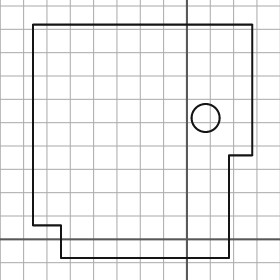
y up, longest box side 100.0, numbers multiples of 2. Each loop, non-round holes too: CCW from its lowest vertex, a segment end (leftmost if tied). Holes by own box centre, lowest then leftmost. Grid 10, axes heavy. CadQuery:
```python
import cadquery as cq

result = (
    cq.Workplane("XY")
    .moveTo(-54.0, -8.0)
    .lineTo(18.0, -8.0)
    .lineTo(18.0, 36.0)
    .lineTo(28.0, 36.0)
    .lineTo(28.0, 92.0)
    .lineTo(-66.0, 92.0)
    .lineTo(-66.0, 6.0)
    .lineTo(-54.0, 6.0)
    .close()
    .moveTo(8.0, 52.0)
    .circle(6.0)
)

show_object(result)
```